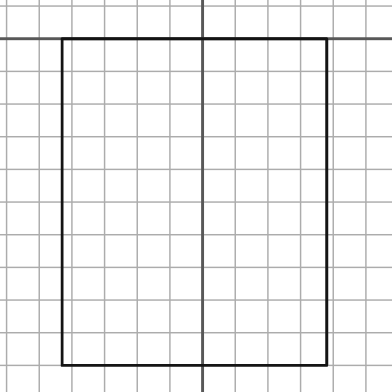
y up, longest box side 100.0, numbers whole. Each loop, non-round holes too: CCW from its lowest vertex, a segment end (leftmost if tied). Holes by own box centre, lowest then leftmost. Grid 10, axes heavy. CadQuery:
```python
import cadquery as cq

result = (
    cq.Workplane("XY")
    .moveTo(-43.0, -100.0)
    .lineTo(38.0, -100.0)
    .lineTo(38.0, 0.0)
    .lineTo(-43.0, 0.0)
    .close()
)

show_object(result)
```